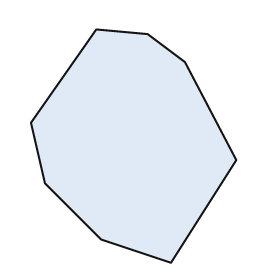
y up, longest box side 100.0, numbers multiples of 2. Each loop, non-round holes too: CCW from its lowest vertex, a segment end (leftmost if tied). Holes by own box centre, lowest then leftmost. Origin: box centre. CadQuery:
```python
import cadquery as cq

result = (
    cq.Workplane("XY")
    .moveTo(16.0, -50.0)
    .lineTo(44.0, -6.0)
    .lineTo(22.0, 36.0)
    .lineTo(6.0, 48.0)
    .lineTo(-16.0, 50.0)
    .lineTo(-44.0, 10.0)
    .lineTo(-38.0, -16.0)
    .lineTo(-14.0, -40.0)
    .close()
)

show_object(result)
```